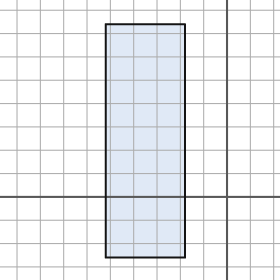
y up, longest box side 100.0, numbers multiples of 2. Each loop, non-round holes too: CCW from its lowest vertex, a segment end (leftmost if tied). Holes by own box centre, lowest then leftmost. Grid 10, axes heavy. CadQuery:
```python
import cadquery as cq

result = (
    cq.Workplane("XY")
    .moveTo(-52.0, -26.0)
    .lineTo(-18.0, -26.0)
    .lineTo(-18.0, 74.0)
    .lineTo(-52.0, 74.0)
    .close()
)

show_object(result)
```